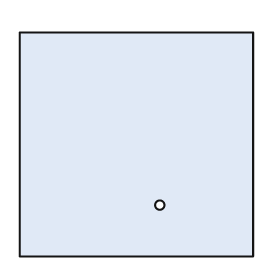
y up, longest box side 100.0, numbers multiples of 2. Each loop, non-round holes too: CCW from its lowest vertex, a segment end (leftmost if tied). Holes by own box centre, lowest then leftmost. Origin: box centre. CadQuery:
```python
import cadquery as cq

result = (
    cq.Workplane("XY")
    .moveTo(-50.0, -48.0)
    .lineTo(50.0, -48.0)
    .lineTo(50.0, 48.0)
    .lineTo(-50.0, 48.0)
    .close()
    .moveTo(10.0, -26.0)
    .circle(2.0)
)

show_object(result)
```